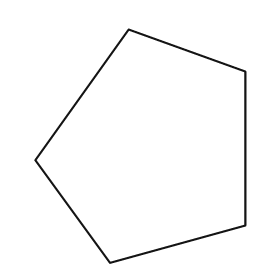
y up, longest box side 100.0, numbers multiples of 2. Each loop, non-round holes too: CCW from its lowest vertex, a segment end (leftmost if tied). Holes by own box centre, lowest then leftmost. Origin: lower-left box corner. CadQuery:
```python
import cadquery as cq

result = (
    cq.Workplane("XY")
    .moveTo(32.0, 0.0)
    .lineTo(90.0, 16.0)
    .lineTo(90.0, 82.0)
    .lineTo(40.0, 100.0)
    .lineTo(0.0, 44.0)
    .close()
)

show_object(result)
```